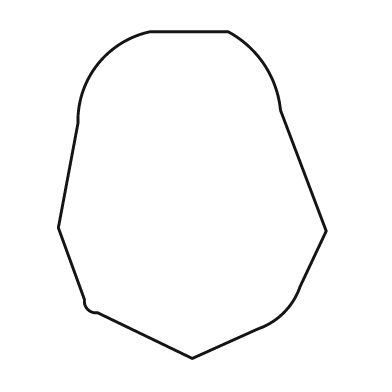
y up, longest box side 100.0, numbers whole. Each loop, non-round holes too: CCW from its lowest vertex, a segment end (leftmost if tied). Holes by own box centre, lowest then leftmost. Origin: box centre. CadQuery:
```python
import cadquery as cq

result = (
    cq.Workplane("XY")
    .moveTo(0.0, -50.0)
    .lineTo(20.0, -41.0)
    .threePointArc((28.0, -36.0), (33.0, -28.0))
    .lineTo(41.0, -11.0)
    .lineTo(27.0, 26.0)
    .threePointArc((22.0, 40.0), (11.0, 50.0))
    .lineTo(-13.0, 50.0)
    .threePointArc((-29.0, 40.0), (-35.0, 22.0))
    .lineTo(-41.0, -10.0)
    .lineTo(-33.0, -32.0)
    .threePointArc((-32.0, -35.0), (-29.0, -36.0))
    .close()
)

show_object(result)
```